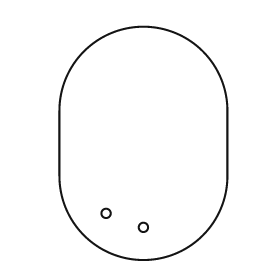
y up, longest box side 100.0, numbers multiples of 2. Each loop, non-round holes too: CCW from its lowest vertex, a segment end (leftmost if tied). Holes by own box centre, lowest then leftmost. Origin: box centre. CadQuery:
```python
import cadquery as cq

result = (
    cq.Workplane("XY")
    .moveTo(-36.0, -14.0)
    .threePointArc((0.0, -50.0), (36.0, -14.0))
    .lineTo(36.0, 14.0)
    .threePointArc((0.0, 50.0), (-36.0, 14.0))
    .close()
    .moveTo(0.0, -36.0)
    .circle(2.0)
    .moveTo(-16.0, -30.0)
    .circle(2.0)
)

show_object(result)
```